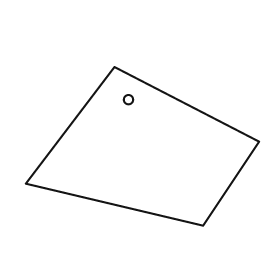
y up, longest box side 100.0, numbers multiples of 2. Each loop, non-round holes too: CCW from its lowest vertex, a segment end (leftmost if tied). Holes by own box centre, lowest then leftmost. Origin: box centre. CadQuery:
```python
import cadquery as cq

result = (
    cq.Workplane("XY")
    .moveTo(26.0, -34.0)
    .lineTo(50.0, 2.0)
    .lineTo(-12.0, 34.0)
    .lineTo(-50.0, -16.0)
    .close()
    .moveTo(-6.0, 20.0)
    .circle(2.0)
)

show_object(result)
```